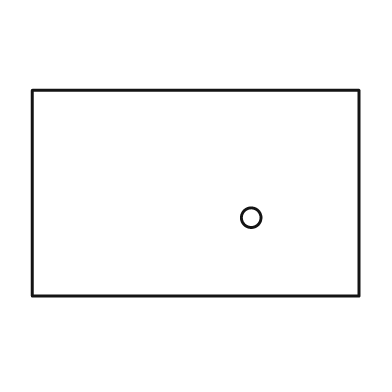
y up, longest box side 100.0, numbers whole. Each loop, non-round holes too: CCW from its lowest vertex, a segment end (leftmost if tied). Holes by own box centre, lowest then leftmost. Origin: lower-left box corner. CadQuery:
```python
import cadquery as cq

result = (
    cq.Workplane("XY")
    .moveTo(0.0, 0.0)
    .lineTo(100.0, 0.0)
    .lineTo(100.0, 63.0)
    .lineTo(0.0, 63.0)
    .close()
    .moveTo(67.0, 24.0)
    .circle(3.0)
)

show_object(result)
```